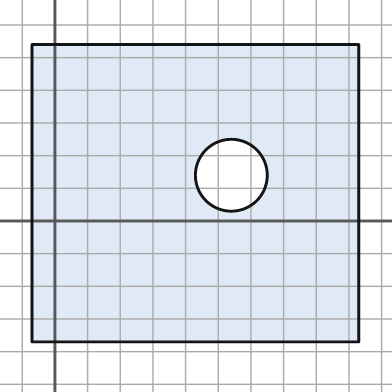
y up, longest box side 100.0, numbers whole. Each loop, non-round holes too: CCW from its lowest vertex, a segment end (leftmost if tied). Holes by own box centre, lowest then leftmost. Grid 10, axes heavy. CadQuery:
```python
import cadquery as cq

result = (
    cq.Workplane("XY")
    .moveTo(-7.0, -37.0)
    .lineTo(93.0, -37.0)
    .lineTo(93.0, 54.0)
    .lineTo(-7.0, 54.0)
    .close()
    .moveTo(54.0, 14.0)
    .circle(11.0)
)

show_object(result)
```